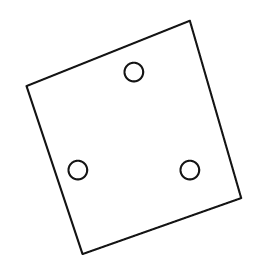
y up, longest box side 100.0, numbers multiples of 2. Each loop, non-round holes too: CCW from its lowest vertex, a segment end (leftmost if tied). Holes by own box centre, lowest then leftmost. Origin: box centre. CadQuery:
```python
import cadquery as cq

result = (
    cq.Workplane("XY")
    .moveTo(-22.0, -50.0)
    .lineTo(46.0, -26.0)
    .lineTo(24.0, 50.0)
    .lineTo(-46.0, 22.0)
    .close()
    .moveTo(-24.0, -14.0)
    .circle(4.0)
    .moveTo(24.0, -14.0)
    .circle(4.0)
    .moveTo(0.0, 28.0)
    .circle(4.0)
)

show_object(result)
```